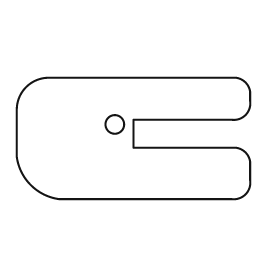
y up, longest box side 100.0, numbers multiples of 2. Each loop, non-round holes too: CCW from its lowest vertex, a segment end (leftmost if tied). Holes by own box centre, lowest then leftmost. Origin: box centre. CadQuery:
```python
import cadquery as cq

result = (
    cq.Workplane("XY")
    .moveTo(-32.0, -26.0)
    .lineTo(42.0, -26.0)
    .threePointArc((48.0, -24.0), (50.0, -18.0))
    .lineTo(50.0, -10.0)
    .threePointArc((48.0, -6.0), (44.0, -4.0))
    .lineTo(0.0, -4.0)
    .lineTo(0.0, 8.0)
    .lineTo(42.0, 8.0)
    .threePointArc((48.0, 10.0), (50.0, 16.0))
    .lineTo(50.0, 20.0)
    .threePointArc((48.0, 24.0), (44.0, 26.0))
    .lineTo(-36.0, 26.0)
    .threePointArc((-46.0, 22.0), (-50.0, 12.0))
    .lineTo(-50.0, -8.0)
    .threePointArc((-44.0, -20.0), (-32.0, -26.0))
    .close()
    .moveTo(-8.0, 6.0)
    .circle(4.0)
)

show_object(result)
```